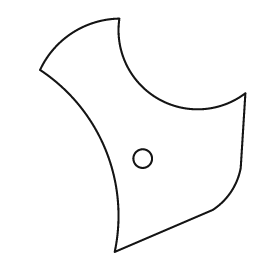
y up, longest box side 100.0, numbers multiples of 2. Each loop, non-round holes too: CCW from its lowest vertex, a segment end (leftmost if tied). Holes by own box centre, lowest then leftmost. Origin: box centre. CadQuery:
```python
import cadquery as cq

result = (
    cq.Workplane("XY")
    .moveTo(-12.0, -50.0)
    .lineTo(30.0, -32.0)
    .threePointArc((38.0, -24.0), (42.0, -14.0))
    .lineTo(44.0, 18.0)
    .threePointArc((6.0, 16.0), (-10.0, 50.0))
    .threePointArc((-30.0, 44.0), (-44.0, 28.0))
    .threePointArc((-16.0, -6.0), (-12.0, -50.0))
    .close()
    .moveTo(0.0, -10.0)
    .circle(4.0)
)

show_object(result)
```